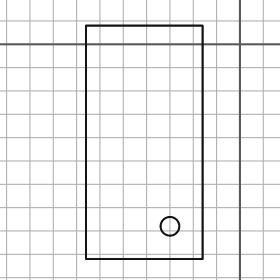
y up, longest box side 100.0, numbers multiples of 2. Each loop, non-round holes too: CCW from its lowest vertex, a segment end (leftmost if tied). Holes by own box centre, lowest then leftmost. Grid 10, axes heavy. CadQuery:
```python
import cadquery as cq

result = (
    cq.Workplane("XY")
    .moveTo(-66.0, -92.0)
    .lineTo(-16.0, -92.0)
    .lineTo(-16.0, 8.0)
    .lineTo(-66.0, 8.0)
    .close()
    .moveTo(-30.0, -78.0)
    .circle(4.0)
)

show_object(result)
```